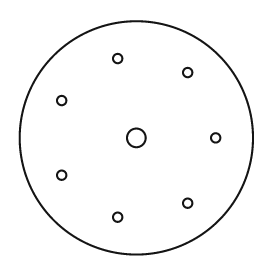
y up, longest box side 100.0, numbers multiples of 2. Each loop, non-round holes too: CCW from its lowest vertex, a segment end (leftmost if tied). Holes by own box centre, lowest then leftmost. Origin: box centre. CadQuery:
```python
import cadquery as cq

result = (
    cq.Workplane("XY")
    .moveTo(0.0, 0.0)
    .circle(50.0)
    .moveTo(-8.0, -34.0)
    .circle(2.0)
    .moveTo(22.0, -28.0)
    .circle(2.0)
    .moveTo(-32.0, -16.0)
    .circle(2.0)
    .moveTo(0.0, 0.0)
    .circle(4.0)
    .moveTo(34.0, 0.0)
    .circle(2.0)
    .moveTo(-32.0, 16.0)
    .circle(2.0)
    .moveTo(22.0, 28.0)
    .circle(2.0)
    .moveTo(-8.0, 34.0)
    .circle(2.0)
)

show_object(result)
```